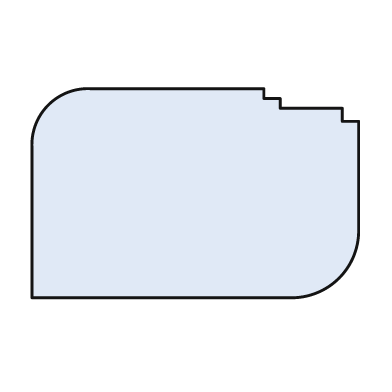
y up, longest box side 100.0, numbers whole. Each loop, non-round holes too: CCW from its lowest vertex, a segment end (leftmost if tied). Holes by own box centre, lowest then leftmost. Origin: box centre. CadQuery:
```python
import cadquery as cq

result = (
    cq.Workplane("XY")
    .moveTo(-50.0, -32.0)
    .lineTo(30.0, -32.0)
    .threePointArc((44.0, -26.0), (50.0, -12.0))
    .lineTo(50.0, 22.0)
    .lineTo(45.0, 22.0)
    .lineTo(45.0, 26.0)
    .lineTo(26.0, 26.0)
    .lineTo(26.0, 29.0)
    .lineTo(21.0, 29.0)
    .lineTo(21.0, 32.0)
    .lineTo(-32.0, 32.0)
    .threePointArc((-45.0, 27.0), (-50.0, 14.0))
    .close()
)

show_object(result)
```